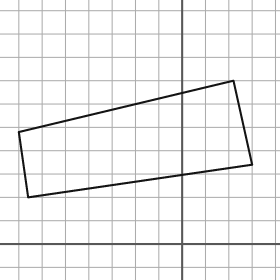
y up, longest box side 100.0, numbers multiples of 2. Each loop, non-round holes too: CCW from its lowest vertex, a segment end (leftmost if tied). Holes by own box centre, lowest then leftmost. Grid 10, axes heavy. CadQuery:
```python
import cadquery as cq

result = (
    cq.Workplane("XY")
    .moveTo(-66.0, 20.0)
    .lineTo(30.0, 34.0)
    .lineTo(22.0, 70.0)
    .lineTo(-70.0, 48.0)
    .close()
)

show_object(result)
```